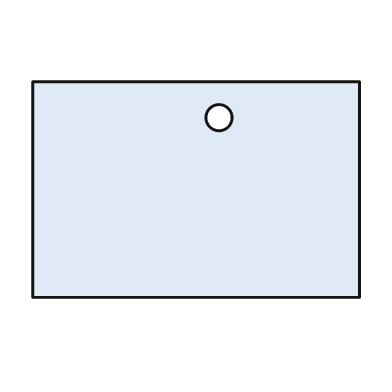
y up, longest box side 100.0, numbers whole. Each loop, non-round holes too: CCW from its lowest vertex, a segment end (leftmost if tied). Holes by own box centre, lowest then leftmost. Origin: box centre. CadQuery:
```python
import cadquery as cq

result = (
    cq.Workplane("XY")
    .moveTo(-50.0, -33.0)
    .lineTo(50.0, -33.0)
    .lineTo(50.0, 33.0)
    .lineTo(-50.0, 33.0)
    .close()
    .moveTo(7.0, 22.0)
    .circle(4.0)
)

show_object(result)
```